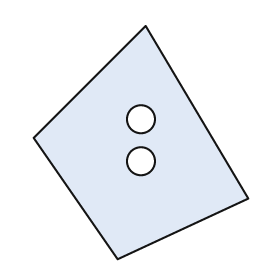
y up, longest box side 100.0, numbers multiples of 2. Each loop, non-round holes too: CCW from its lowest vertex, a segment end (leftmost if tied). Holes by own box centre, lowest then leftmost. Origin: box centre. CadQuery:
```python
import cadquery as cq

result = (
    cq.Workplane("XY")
    .moveTo(-10.0, -50.0)
    .lineTo(46.0, -24.0)
    .lineTo(2.0, 50.0)
    .lineTo(-46.0, 2.0)
    .close()
    .moveTo(0.0, -8.0)
    .circle(6.0)
    .moveTo(0.0, 10.0)
    .circle(6.0)
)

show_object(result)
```